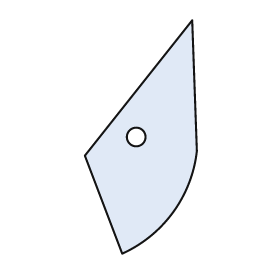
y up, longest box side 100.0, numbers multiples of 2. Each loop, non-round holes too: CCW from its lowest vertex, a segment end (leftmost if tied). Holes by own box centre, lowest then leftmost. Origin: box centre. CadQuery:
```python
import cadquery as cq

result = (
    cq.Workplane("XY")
    .moveTo(-8.0, -50.0)
    .threePointArc((14.0, -32.0), (24.0, -6.0))
    .lineTo(22.0, 50.0)
    .lineTo(-24.0, -8.0)
    .close()
    .moveTo(-2.0, 0.0)
    .circle(4.0)
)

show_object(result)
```